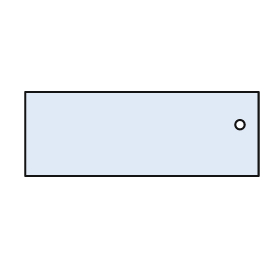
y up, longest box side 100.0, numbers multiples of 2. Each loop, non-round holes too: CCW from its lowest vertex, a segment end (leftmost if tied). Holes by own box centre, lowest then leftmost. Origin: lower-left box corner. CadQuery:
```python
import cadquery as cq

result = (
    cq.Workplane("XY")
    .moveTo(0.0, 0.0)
    .lineTo(100.0, 0.0)
    .lineTo(100.0, 36.0)
    .lineTo(0.0, 36.0)
    .close()
    .moveTo(92.0, 22.0)
    .circle(2.0)
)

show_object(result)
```